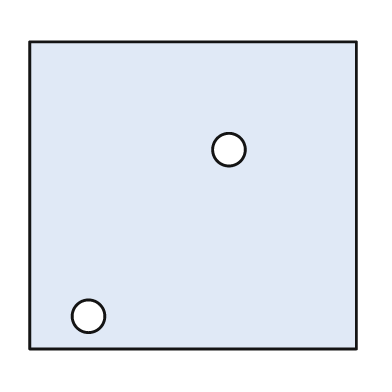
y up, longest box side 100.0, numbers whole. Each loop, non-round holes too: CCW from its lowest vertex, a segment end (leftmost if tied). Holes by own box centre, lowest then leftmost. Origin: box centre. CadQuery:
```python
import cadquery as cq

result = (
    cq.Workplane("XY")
    .moveTo(-50.0, -47.0)
    .lineTo(50.0, -47.0)
    .lineTo(50.0, 47.0)
    .lineTo(-50.0, 47.0)
    .close()
    .moveTo(-32.0, -37.0)
    .circle(5.0)
    .moveTo(11.0, 14.0)
    .circle(5.0)
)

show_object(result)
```